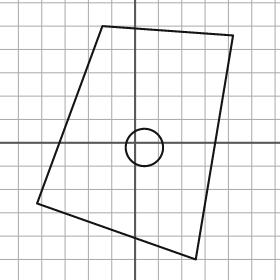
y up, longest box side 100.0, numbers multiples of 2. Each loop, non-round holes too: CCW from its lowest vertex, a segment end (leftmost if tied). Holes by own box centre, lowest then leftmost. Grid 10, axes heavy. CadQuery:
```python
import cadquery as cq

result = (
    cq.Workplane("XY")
    .moveTo(26.0, -50.0)
    .lineTo(42.0, 46.0)
    .lineTo(-14.0, 50.0)
    .lineTo(-42.0, -26.0)
    .close()
    .moveTo(4.0, -2.0)
    .circle(8.0)
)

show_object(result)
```